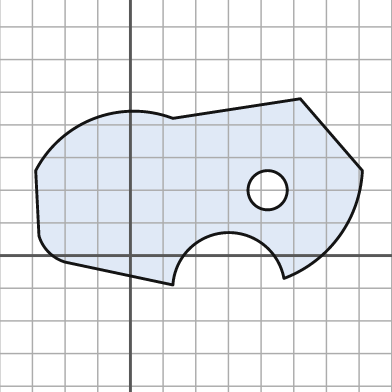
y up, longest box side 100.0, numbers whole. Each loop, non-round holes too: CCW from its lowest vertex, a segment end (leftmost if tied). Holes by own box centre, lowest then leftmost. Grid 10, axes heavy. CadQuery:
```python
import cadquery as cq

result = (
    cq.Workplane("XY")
    .moveTo(13.0, -9.0)
    .threePointArc((29.0, 7.0), (47.0, -7.0))
    .threePointArc((64.0, 6.0), (71.0, 26.0))
    .lineTo(52.0, 48.0)
    .lineTo(13.0, 42.0)
    .threePointArc((-11.0, 42.0), (-29.0, 26.0))
    .lineTo(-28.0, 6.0)
    .threePointArc((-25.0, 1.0), (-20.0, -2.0))
    .close()
    .moveTo(42.0, 20.0)
    .circle(6.0)
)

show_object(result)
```